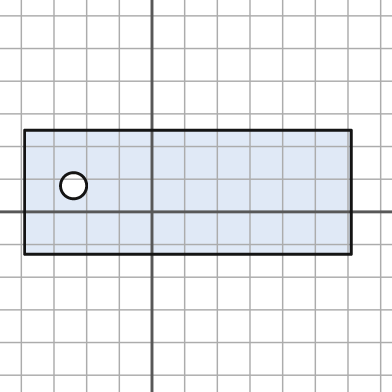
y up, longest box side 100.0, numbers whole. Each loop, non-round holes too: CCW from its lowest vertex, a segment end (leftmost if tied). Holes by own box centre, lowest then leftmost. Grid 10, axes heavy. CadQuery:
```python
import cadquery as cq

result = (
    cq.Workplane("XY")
    .moveTo(-39.0, -13.0)
    .lineTo(61.0, -13.0)
    .lineTo(61.0, 25.0)
    .lineTo(-39.0, 25.0)
    .close()
    .moveTo(-24.0, 8.0)
    .circle(4.0)
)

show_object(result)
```